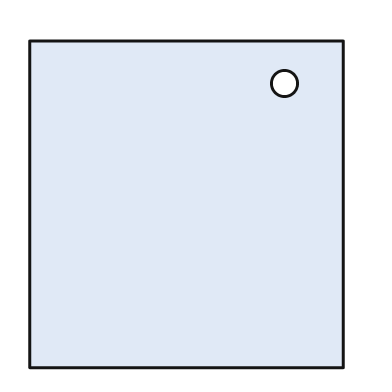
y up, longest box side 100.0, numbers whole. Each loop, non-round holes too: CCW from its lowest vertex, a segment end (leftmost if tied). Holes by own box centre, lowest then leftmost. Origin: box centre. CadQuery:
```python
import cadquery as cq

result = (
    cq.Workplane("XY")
    .moveTo(-48.0, -50.0)
    .lineTo(48.0, -50.0)
    .lineTo(48.0, 50.0)
    .lineTo(-48.0, 50.0)
    .close()
    .moveTo(30.0, 37.0)
    .circle(4.0)
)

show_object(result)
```